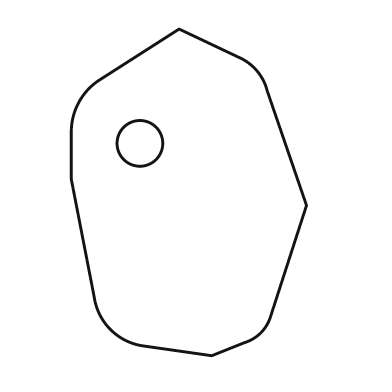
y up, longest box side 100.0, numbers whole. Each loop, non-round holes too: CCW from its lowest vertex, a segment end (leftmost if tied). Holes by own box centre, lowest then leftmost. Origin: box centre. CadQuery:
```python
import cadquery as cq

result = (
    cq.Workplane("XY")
    .moveTo(7.0, -50.0)
    .lineTo(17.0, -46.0)
    .threePointArc((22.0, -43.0), (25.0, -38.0))
    .lineTo(36.0, -4.0)
    .lineTo(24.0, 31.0)
    .threePointArc((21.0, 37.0), (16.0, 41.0))
    .lineTo(-3.0, 50.0)
    .lineTo(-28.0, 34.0)
    .threePointArc((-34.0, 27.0), (-36.0, 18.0))
    .lineTo(-36.0, 4.0)
    .lineTo(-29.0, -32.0)
    .threePointArc((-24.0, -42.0), (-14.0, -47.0))
    .close()
    .moveTo(-15.0, 15.0)
    .circle(7.0)
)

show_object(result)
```